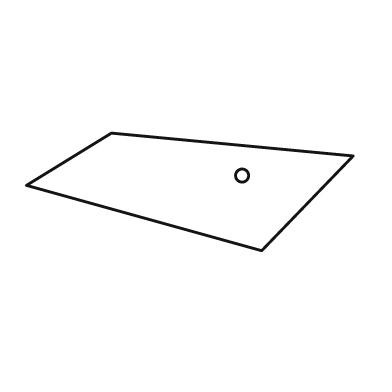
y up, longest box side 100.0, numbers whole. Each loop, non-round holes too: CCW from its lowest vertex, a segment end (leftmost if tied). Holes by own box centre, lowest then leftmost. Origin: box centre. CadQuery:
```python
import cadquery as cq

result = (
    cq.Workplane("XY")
    .moveTo(22.0, -18.0)
    .lineTo(50.0, 11.0)
    .lineTo(-24.0, 18.0)
    .lineTo(-50.0, 2.0)
    .close()
    .moveTo(16.0, 5.0)
    .circle(2.0)
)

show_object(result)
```